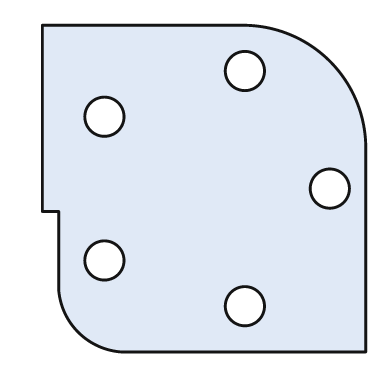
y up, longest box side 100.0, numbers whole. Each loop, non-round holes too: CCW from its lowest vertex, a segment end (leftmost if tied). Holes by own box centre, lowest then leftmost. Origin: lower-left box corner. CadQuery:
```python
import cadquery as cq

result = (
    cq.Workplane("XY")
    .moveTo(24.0, 0.0)
    .lineTo(99.0, 0.0)
    .lineTo(99.0, 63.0)
    .threePointArc((88.0, 89.0), (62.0, 100.0))
    .lineTo(0.0, 100.0)
    .lineTo(0.0, 43.0)
    .lineTo(5.0, 43.0)
    .lineTo(5.0, 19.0)
    .threePointArc((11.0, 6.0), (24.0, 0.0))
    .close()
    .moveTo(62.0, 14.0)
    .circle(6.0)
    .moveTo(19.0, 28.0)
    .circle(6.0)
    .moveTo(88.0, 50.0)
    .circle(6.0)
    .moveTo(19.0, 72.0)
    .circle(6.0)
    .moveTo(62.0, 86.0)
    .circle(6.0)
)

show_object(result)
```